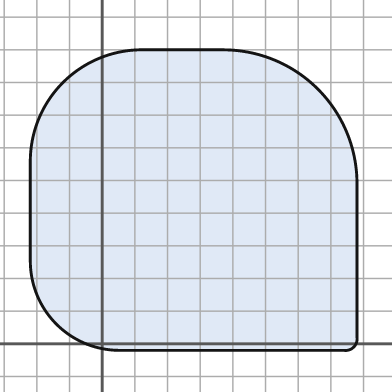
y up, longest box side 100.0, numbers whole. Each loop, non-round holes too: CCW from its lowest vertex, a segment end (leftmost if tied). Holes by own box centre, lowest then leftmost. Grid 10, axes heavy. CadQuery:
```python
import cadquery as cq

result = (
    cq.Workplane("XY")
    .moveTo(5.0, -2.0)
    .lineTo(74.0, -2.0)
    .threePointArc((77.0, -1.0), (78.0, 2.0))
    .lineTo(78.0, 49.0)
    .threePointArc((66.0, 78.0), (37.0, 90.0))
    .lineTo(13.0, 90.0)
    .threePointArc((-12.0, 80.0), (-22.0, 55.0))
    .lineTo(-22.0, 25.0)
    .threePointArc((-14.0, 6.0), (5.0, -2.0))
    .close()
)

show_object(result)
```